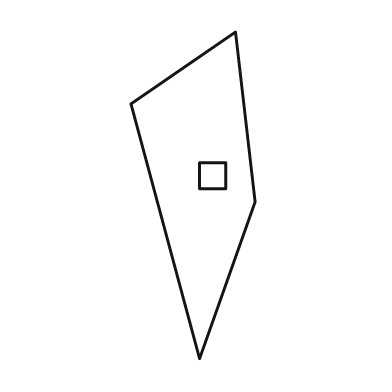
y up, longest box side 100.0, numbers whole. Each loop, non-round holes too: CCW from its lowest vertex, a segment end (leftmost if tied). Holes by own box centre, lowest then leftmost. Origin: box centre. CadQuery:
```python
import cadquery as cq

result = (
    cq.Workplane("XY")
    .moveTo(2.0, -50.0)
    .lineTo(19.0, -2.0)
    .lineTo(13.0, 50.0)
    .lineTo(-19.0, 28.0)
    .close()
    .moveTo(2.0, 2.0)
    .lineTo(10.0, 2.0)
    .lineTo(10.0, 10.0)
    .lineTo(2.0, 10.0)
    .close()
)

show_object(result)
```